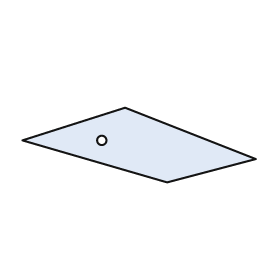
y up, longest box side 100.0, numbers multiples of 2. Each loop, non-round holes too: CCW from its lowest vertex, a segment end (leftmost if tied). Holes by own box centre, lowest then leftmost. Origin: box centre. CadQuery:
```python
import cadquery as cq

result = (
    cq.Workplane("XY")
    .moveTo(12.0, -16.0)
    .lineTo(50.0, -6.0)
    .lineTo(-6.0, 16.0)
    .lineTo(-50.0, 2.0)
    .close()
    .moveTo(-16.0, 2.0)
    .circle(2.0)
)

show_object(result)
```